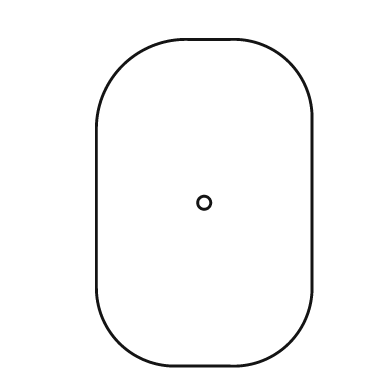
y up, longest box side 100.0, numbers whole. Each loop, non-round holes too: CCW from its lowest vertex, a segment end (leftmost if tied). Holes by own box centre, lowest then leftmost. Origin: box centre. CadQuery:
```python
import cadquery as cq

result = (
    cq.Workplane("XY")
    .moveTo(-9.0, -50.0)
    .lineTo(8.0, -50.0)
    .threePointArc((26.0, -43.0), (33.0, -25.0))
    .lineTo(33.0, 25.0)
    .threePointArc((26.0, 43.0), (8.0, 50.0))
    .lineTo(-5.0, 50.0)
    .threePointArc((-25.0, 42.0), (-33.0, 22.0))
    .lineTo(-33.0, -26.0)
    .threePointArc((-26.0, -43.0), (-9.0, -50.0))
    .close()
    .moveTo(0.0, 0.0)
    .circle(2.0)
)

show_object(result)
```